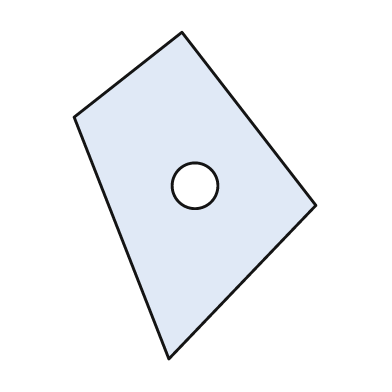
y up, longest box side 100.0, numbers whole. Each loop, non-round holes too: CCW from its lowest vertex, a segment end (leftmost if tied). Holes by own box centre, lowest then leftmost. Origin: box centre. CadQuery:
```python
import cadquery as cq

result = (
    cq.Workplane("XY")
    .moveTo(-8.0, -50.0)
    .lineTo(37.0, -3.0)
    .lineTo(-4.0, 50.0)
    .lineTo(-37.0, 24.0)
    .close()
    .moveTo(0.0, 3.0)
    .circle(7.0)
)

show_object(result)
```